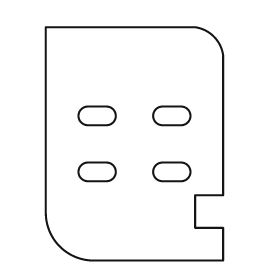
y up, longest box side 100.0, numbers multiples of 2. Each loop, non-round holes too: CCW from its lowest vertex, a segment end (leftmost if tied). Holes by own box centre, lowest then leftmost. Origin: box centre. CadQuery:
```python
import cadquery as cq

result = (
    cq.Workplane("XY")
    .moveTo(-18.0, -50.0)
    .lineTo(38.0, -50.0)
    .lineTo(38.0, -36.0)
    .lineTo(26.0, -36.0)
    .lineTo(26.0, -22.0)
    .lineTo(38.0, -22.0)
    .lineTo(38.0, 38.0)
    .threePointArc((34.0, 46.0), (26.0, 50.0))
    .lineTo(-38.0, 50.0)
    .lineTo(-38.0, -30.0)
    .threePointArc((-32.0, -44.0), (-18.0, -50.0))
    .close()
    .moveTo(-20.0, -16.0)
    .lineTo(-12.0, -16.0)
    .threePointArc((-8.0, -12.0), (-12.0, -8.0))
    .lineTo(-20.0, -8.0)
    .threePointArc((-24.0, -12.0), (-20.0, -16.0))
    .close()
    .moveTo(12.0, -16.0)
    .lineTo(20.0, -16.0)
    .threePointArc((24.0, -12.0), (20.0, -8.0))
    .lineTo(12.0, -8.0)
    .threePointArc((8.0, -12.0), (12.0, -16.0))
    .close()
    .moveTo(-20.0, 8.0)
    .lineTo(-12.0, 8.0)
    .threePointArc((-8.0, 12.0), (-12.0, 16.0))
    .lineTo(-20.0, 16.0)
    .threePointArc((-24.0, 12.0), (-20.0, 8.0))
    .close()
    .moveTo(12.0, 8.0)
    .lineTo(20.0, 8.0)
    .threePointArc((24.0, 12.0), (20.0, 16.0))
    .lineTo(12.0, 16.0)
    .threePointArc((8.0, 12.0), (12.0, 8.0))
    .close()
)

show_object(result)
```